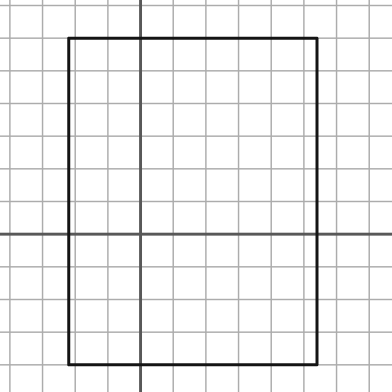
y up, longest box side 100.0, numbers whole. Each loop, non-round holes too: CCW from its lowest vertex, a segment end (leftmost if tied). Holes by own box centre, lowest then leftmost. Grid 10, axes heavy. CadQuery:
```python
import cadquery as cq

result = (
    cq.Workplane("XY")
    .moveTo(-22.0, -40.0)
    .lineTo(54.0, -40.0)
    .lineTo(54.0, 60.0)
    .lineTo(-22.0, 60.0)
    .close()
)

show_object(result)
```